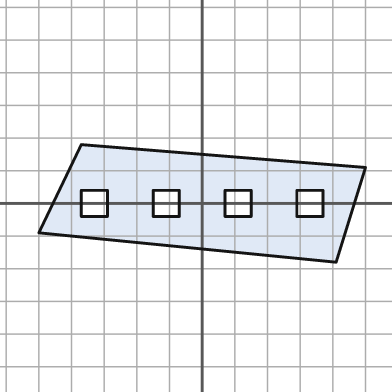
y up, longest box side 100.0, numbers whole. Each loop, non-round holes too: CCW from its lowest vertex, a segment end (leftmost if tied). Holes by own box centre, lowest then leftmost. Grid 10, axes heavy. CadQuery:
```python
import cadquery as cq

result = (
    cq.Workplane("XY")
    .moveTo(41.0, -18.0)
    .lineTo(50.0, 11.0)
    .lineTo(-37.0, 18.0)
    .lineTo(-50.0, -9.0)
    .close()
    .moveTo(-37.0, -4.0)
    .lineTo(-29.0, -4.0)
    .lineTo(-29.0, 4.0)
    .lineTo(-37.0, 4.0)
    .close()
    .moveTo(-15.0, -4.0)
    .lineTo(-7.0, -4.0)
    .lineTo(-7.0, 4.0)
    .lineTo(-15.0, 4.0)
    .close()
    .moveTo(7.0, -4.0)
    .lineTo(15.0, -4.0)
    .lineTo(15.0, 4.0)
    .lineTo(7.0, 4.0)
    .close()
    .moveTo(29.0, -4.0)
    .lineTo(37.0, -4.0)
    .lineTo(37.0, 4.0)
    .lineTo(29.0, 4.0)
    .close()
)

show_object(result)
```